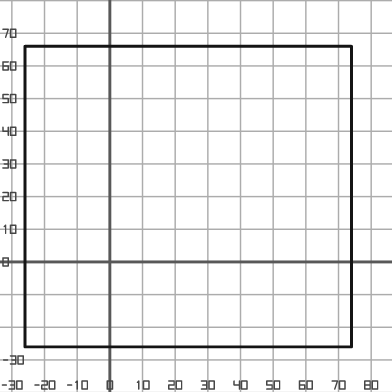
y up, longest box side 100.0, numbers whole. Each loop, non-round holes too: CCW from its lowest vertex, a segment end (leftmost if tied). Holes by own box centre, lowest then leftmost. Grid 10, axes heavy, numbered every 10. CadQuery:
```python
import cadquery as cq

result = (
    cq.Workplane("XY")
    .moveTo(-26.0, -26.0)
    .lineTo(74.0, -26.0)
    .lineTo(74.0, 66.0)
    .lineTo(-26.0, 66.0)
    .close()
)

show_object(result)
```